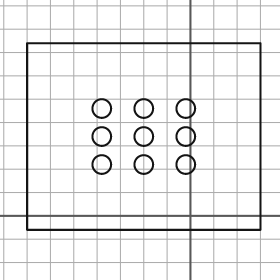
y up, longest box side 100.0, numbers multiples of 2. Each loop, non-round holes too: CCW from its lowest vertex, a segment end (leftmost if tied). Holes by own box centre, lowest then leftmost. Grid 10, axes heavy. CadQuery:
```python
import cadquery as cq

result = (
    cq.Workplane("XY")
    .moveTo(-70.0, -6.0)
    .lineTo(30.0, -6.0)
    .lineTo(30.0, 74.0)
    .lineTo(-70.0, 74.0)
    .close()
    .moveTo(-38.0, 22.0)
    .circle(4.0)
    .moveTo(-20.0, 22.0)
    .circle(4.0)
    .moveTo(-2.0, 22.0)
    .circle(4.0)
    .moveTo(-38.0, 34.0)
    .circle(4.0)
    .moveTo(-20.0, 34.0)
    .circle(4.0)
    .moveTo(-2.0, 34.0)
    .circle(4.0)
    .moveTo(-38.0, 46.0)
    .circle(4.0)
    .moveTo(-20.0, 46.0)
    .circle(4.0)
    .moveTo(-2.0, 46.0)
    .circle(4.0)
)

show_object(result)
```